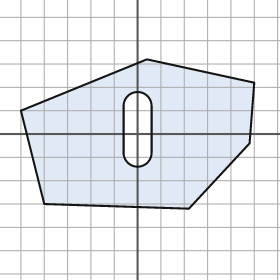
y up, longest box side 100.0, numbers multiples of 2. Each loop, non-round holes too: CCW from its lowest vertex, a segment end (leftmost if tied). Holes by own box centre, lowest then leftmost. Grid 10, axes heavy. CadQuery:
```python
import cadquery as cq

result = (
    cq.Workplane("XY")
    .moveTo(22.0, -32.0)
    .lineTo(48.0, -4.0)
    .lineTo(50.0, 22.0)
    .lineTo(4.0, 32.0)
    .lineTo(-50.0, 10.0)
    .lineTo(-40.0, -30.0)
    .close()
    .moveTo(-6.0, -8.0)
    .threePointArc((0.0, -14.0), (6.0, -8.0))
    .lineTo(6.0, 12.0)
    .threePointArc((0.0, 18.0), (-6.0, 12.0))
    .close()
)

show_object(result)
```